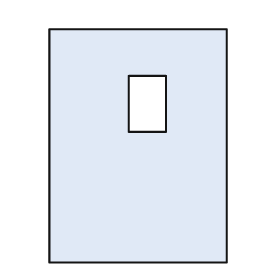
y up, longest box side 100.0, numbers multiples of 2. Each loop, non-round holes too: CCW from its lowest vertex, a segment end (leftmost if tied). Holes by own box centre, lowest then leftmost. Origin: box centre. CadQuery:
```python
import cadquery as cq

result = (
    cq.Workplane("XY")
    .moveTo(-38.0, -50.0)
    .lineTo(38.0, -50.0)
    .lineTo(38.0, 50.0)
    .lineTo(-38.0, 50.0)
    .close()
    .moveTo(-4.0, 6.0)
    .lineTo(12.0, 6.0)
    .lineTo(12.0, 30.0)
    .lineTo(-4.0, 30.0)
    .close()
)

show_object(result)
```